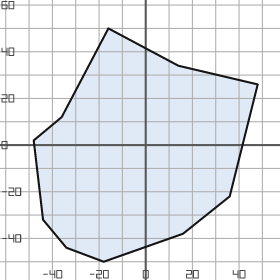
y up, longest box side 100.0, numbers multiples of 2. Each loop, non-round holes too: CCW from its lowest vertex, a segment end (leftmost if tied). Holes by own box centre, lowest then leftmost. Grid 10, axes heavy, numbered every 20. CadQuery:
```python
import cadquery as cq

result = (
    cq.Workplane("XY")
    .moveTo(-18.0, -50.0)
    .lineTo(16.0, -38.0)
    .lineTo(36.0, -22.0)
    .lineTo(48.0, 26.0)
    .lineTo(14.0, 34.0)
    .lineTo(-16.0, 50.0)
    .lineTo(-36.0, 12.0)
    .lineTo(-48.0, 2.0)
    .lineTo(-44.0, -32.0)
    .lineTo(-34.0, -44.0)
    .close()
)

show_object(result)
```